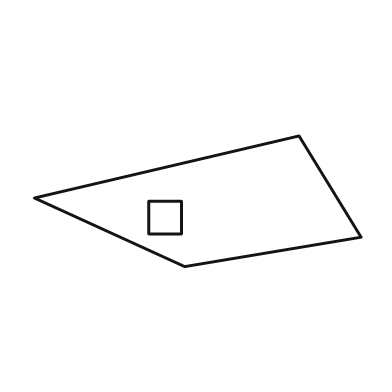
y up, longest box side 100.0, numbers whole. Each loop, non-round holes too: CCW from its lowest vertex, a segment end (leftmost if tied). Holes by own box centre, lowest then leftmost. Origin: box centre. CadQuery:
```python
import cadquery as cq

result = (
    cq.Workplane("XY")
    .moveTo(-4.0, -20.0)
    .lineTo(50.0, -11.0)
    .lineTo(31.0, 20.0)
    .lineTo(-50.0, 1.0)
    .close()
    .moveTo(-15.0, -10.0)
    .lineTo(-5.0, -10.0)
    .lineTo(-5.0, 0.0)
    .lineTo(-15.0, 0.0)
    .close()
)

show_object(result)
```